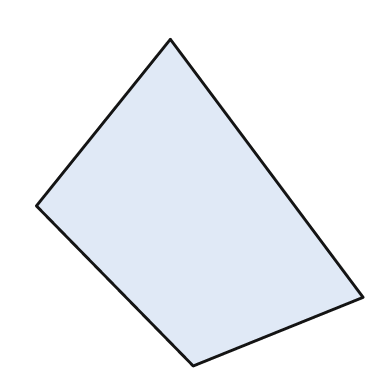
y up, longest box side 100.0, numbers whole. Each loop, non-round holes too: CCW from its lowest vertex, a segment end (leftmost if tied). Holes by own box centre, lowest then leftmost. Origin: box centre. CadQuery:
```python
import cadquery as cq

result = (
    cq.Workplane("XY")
    .moveTo(-2.0, -50.0)
    .lineTo(50.0, -29.0)
    .lineTo(-9.0, 50.0)
    .lineTo(-50.0, -1.0)
    .close()
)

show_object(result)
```